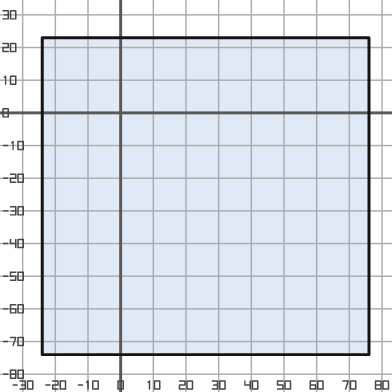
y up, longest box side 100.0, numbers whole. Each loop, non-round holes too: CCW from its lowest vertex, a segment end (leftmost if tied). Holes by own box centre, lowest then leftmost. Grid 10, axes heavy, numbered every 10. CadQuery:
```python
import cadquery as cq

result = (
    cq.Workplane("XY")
    .moveTo(-24.0, -74.0)
    .lineTo(76.0, -74.0)
    .lineTo(76.0, 23.0)
    .lineTo(-24.0, 23.0)
    .close()
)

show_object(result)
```